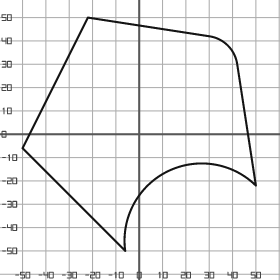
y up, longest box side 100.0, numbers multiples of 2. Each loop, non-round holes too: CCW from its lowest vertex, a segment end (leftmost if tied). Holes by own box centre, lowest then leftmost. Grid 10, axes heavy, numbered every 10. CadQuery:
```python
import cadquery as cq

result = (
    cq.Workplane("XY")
    .moveTo(-6.0, -50.0)
    .threePointArc((12.0, -16.0), (50.0, -22.0))
    .lineTo(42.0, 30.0)
    .threePointArc((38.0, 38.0), (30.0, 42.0))
    .lineTo(-22.0, 50.0)
    .lineTo(-50.0, -6.0)
    .close()
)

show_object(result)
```